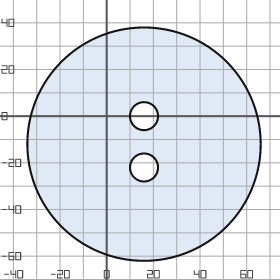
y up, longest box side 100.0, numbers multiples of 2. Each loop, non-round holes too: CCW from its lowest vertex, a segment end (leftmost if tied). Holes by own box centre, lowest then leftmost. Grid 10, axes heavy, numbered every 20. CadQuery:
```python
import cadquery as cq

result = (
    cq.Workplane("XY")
    .moveTo(16.0, -12.0)
    .circle(50.0)
    .moveTo(16.0, -22.0)
    .circle(6.0)
    .moveTo(16.0, 0.0)
    .circle(6.0)
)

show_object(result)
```